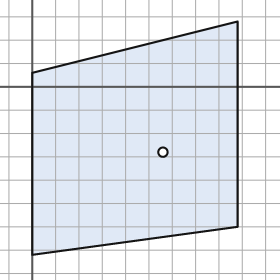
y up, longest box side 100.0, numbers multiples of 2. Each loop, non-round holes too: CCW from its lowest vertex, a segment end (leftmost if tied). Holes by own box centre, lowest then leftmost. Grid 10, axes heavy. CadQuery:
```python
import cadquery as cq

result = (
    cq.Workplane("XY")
    .moveTo(0.0, -72.0)
    .lineTo(88.0, -60.0)
    .lineTo(88.0, 28.0)
    .lineTo(0.0, 6.0)
    .close()
    .moveTo(56.0, -28.0)
    .circle(2.0)
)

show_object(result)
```